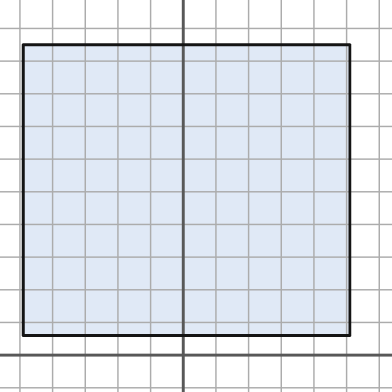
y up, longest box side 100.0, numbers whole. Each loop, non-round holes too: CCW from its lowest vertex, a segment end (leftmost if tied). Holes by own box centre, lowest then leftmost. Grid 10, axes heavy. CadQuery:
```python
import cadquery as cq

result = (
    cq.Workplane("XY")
    .moveTo(-49.0, 6.0)
    .lineTo(51.0, 6.0)
    .lineTo(51.0, 95.0)
    .lineTo(-49.0, 95.0)
    .close()
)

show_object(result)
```